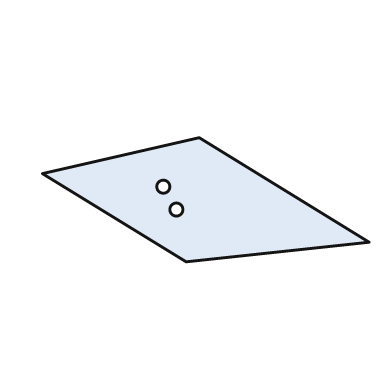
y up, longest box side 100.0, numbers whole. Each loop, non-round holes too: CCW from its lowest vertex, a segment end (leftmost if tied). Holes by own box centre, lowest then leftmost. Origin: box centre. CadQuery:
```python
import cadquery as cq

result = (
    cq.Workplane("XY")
    .moveTo(-6.0, -19.0)
    .lineTo(50.0, -13.0)
    .lineTo(-2.0, 19.0)
    .lineTo(-50.0, 8.0)
    .close()
    .moveTo(-9.0, -3.0)
    .circle(2.0)
    .moveTo(-13.0, 4.0)
    .circle(2.0)
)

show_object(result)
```